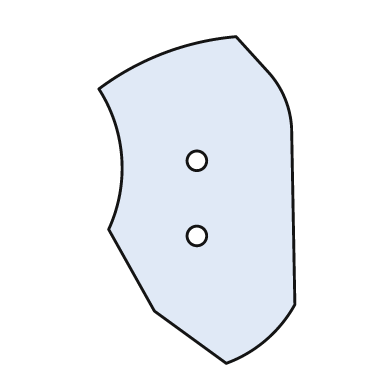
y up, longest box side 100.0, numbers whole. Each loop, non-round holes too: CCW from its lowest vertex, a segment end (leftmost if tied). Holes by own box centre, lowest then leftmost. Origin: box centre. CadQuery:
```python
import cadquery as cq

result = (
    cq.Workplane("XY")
    .moveTo(9.0, -50.0)
    .threePointArc((21.0, -43.0), (30.0, -32.0))
    .lineTo(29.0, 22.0)
    .threePointArc((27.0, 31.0), (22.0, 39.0))
    .lineTo(12.0, 50.0)
    .threePointArc((-10.0, 45.0), (-30.0, 34.0))
    .threePointArc((-23.0, 13.0), (-27.0, -9.0))
    .lineTo(-13.0, -34.0)
    .close()
    .moveTo(0.0, -11.0)
    .circle(3.0)
    .moveTo(0.0, 12.0)
    .circle(3.0)
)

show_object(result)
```